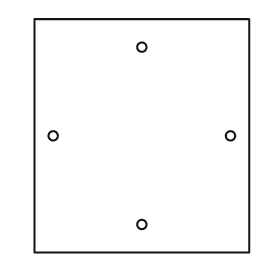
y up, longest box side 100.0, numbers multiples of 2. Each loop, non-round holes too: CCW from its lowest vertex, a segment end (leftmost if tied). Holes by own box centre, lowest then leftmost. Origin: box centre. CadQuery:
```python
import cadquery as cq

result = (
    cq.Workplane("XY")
    .moveTo(-46.0, -50.0)
    .lineTo(46.0, -50.0)
    .lineTo(46.0, 50.0)
    .lineTo(-46.0, 50.0)
    .close()
    .moveTo(0.0, -38.0)
    .circle(2.0)
    .moveTo(-38.0, 0.0)
    .circle(2.0)
    .moveTo(38.0, 0.0)
    .circle(2.0)
    .moveTo(0.0, 38.0)
    .circle(2.0)
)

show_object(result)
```